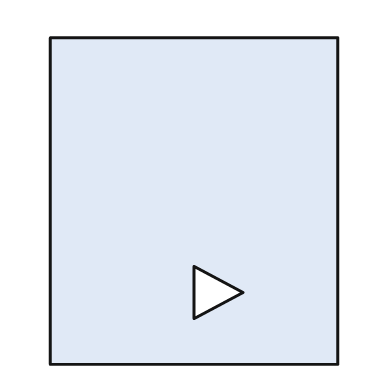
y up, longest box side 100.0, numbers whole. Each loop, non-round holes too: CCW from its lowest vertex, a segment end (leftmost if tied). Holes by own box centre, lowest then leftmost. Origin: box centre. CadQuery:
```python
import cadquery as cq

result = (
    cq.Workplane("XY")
    .moveTo(-44.0, -50.0)
    .lineTo(44.0, -50.0)
    .lineTo(44.0, 50.0)
    .lineTo(-44.0, 50.0)
    .close()
    .moveTo(0.0, -36.0)
    .lineTo(15.0, -28.0)
    .lineTo(0.0, -20.0)
    .close()
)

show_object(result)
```